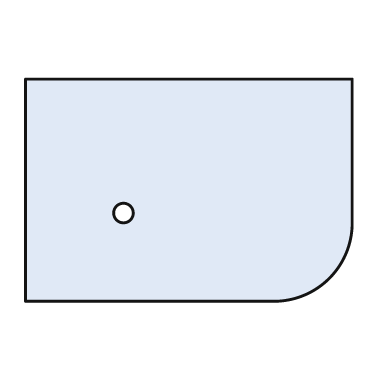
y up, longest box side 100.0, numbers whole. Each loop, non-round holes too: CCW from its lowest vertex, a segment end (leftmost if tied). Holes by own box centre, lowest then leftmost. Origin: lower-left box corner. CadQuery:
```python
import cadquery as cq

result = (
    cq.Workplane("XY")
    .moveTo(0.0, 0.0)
    .lineTo(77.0, 0.0)
    .threePointArc((93.0, 7.0), (100.0, 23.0))
    .lineTo(100.0, 68.0)
    .lineTo(0.0, 68.0)
    .close()
    .moveTo(30.0, 27.0)
    .circle(3.0)
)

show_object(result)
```